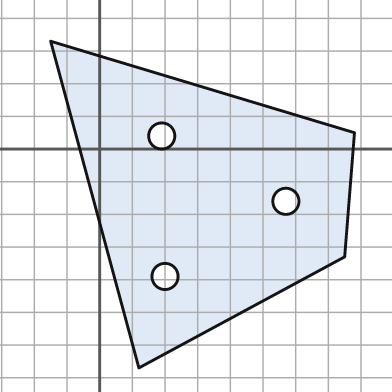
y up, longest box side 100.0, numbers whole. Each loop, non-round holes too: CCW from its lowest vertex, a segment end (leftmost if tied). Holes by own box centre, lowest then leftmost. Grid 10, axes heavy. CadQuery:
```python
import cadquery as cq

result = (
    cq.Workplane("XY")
    .moveTo(12.0, -67.0)
    .lineTo(75.0, -33.0)
    .lineTo(78.0, 5.0)
    .lineTo(-15.0, 33.0)
    .close()
    .moveTo(20.0, -39.0)
    .circle(4.0)
    .moveTo(57.0, -16.0)
    .circle(4.0)
    .moveTo(19.0, 4.0)
    .circle(4.0)
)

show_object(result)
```